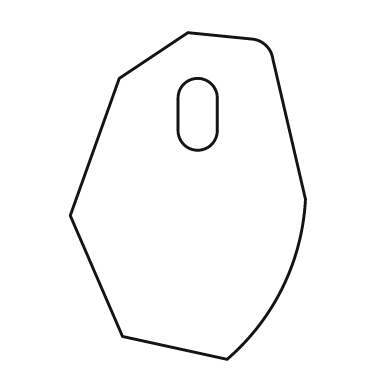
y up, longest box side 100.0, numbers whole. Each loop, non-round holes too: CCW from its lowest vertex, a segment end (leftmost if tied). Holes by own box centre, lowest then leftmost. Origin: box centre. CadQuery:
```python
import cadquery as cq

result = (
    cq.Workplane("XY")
    .moveTo(12.0, -50.0)
    .threePointArc((29.0, -28.0), (36.0, -1.0))
    .lineTo(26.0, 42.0)
    .threePointArc((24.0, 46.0), (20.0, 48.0))
    .lineTo(0.0, 50.0)
    .lineTo(-21.0, 36.0)
    .lineTo(-36.0, -6.0)
    .lineTo(-20.0, -43.0)
    .close()
    .moveTo(-3.0, 20.0)
    .threePointArc((3.0, 14.0), (9.0, 20.0))
    .lineTo(9.0, 30.0)
    .threePointArc((3.0, 36.0), (-3.0, 30.0))
    .close()
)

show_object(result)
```